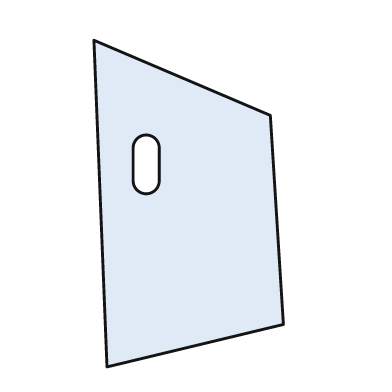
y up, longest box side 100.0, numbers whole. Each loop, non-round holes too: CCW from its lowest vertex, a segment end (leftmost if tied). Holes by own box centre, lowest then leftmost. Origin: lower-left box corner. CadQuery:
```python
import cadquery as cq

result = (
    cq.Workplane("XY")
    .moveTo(4.0, 0.0)
    .lineTo(58.0, 13.0)
    .lineTo(54.0, 77.0)
    .lineTo(0.0, 100.0)
    .close()
    .moveTo(12.0, 57.0)
    .threePointArc((16.0, 53.0), (20.0, 57.0))
    .lineTo(20.0, 67.0)
    .threePointArc((16.0, 71.0), (12.0, 67.0))
    .close()
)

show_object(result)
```